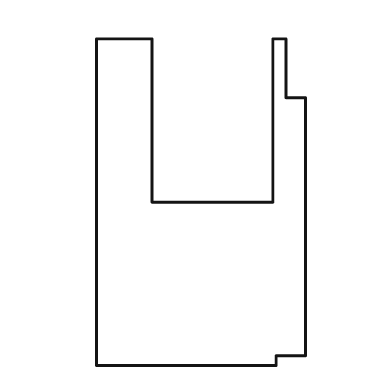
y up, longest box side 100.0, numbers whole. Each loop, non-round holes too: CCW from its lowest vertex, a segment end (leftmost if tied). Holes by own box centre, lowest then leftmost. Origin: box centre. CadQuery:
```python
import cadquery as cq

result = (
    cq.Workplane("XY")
    .moveTo(-32.0, -50.0)
    .lineTo(23.0, -50.0)
    .lineTo(23.0, -47.0)
    .lineTo(32.0, -47.0)
    .lineTo(32.0, 32.0)
    .lineTo(26.0, 32.0)
    .lineTo(26.0, 50.0)
    .lineTo(22.0, 50.0)
    .lineTo(22.0, 0.0)
    .lineTo(-15.0, 0.0)
    .lineTo(-15.0, 50.0)
    .lineTo(-32.0, 50.0)
    .close()
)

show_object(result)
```